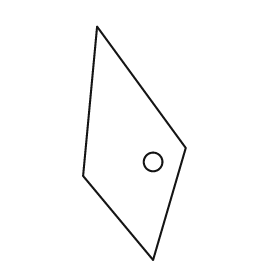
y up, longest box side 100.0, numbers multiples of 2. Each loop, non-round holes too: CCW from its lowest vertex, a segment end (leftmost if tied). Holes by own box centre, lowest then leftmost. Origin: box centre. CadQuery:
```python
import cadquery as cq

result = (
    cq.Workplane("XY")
    .moveTo(8.0, -50.0)
    .lineTo(22.0, -2.0)
    .lineTo(-16.0, 50.0)
    .lineTo(-22.0, -14.0)
    .close()
    .moveTo(8.0, -8.0)
    .circle(4.0)
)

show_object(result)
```